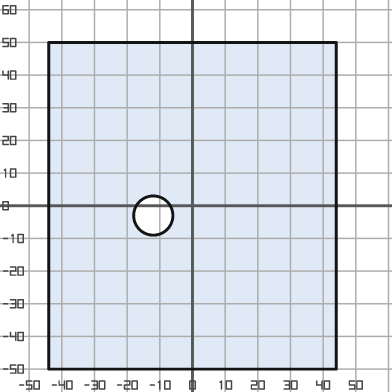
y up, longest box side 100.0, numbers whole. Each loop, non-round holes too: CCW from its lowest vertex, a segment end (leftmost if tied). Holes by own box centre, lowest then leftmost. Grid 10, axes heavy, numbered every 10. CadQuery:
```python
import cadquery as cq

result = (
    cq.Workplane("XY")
    .moveTo(-44.0, -50.0)
    .lineTo(44.0, -50.0)
    .lineTo(44.0, 50.0)
    .lineTo(-44.0, 50.0)
    .close()
    .moveTo(-12.0, -3.0)
    .circle(6.0)
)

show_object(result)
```